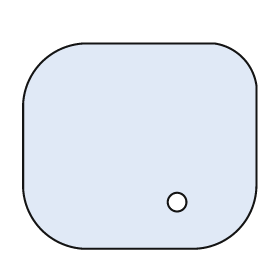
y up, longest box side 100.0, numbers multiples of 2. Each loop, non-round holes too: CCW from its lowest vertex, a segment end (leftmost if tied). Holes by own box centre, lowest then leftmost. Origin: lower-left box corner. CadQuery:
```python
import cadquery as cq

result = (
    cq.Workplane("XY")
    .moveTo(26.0, 0.0)
    .lineTo(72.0, 0.0)
    .threePointArc((92.0, 8.0), (100.0, 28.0))
    .lineTo(100.0, 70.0)
    .threePointArc((94.0, 82.0), (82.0, 88.0))
    .lineTo(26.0, 88.0)
    .threePointArc((8.0, 80.0), (0.0, 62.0))
    .lineTo(0.0, 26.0)
    .threePointArc((8.0, 8.0), (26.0, 0.0))
    .close()
    .moveTo(66.0, 20.0)
    .circle(4.0)
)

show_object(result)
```